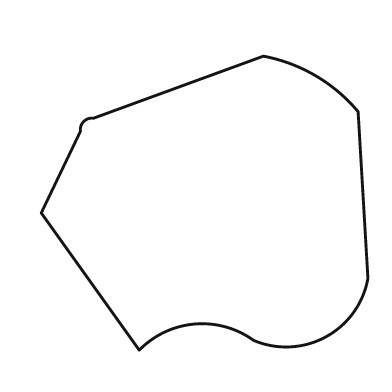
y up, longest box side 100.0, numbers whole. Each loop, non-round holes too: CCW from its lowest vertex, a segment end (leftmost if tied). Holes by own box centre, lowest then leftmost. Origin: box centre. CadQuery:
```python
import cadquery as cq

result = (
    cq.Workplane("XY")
    .moveTo(-20.0, -45.0)
    .threePointArc((-3.0, -37.0), (15.0, -42.0))
    .threePointArc((37.0, -41.0), (50.0, -23.0))
    .lineTo(47.0, 28.0)
    .threePointArc((34.0, 39.0), (18.0, 45.0))
    .lineTo(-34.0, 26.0)
    .threePointArc((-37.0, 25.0), (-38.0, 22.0))
    .lineTo(-50.0, -3.0)
    .close()
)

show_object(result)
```